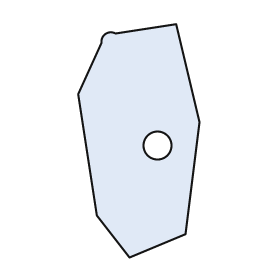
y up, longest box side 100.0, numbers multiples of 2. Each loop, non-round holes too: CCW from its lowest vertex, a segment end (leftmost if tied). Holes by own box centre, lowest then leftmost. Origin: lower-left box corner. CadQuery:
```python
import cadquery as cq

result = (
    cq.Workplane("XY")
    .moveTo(22.0, 0.0)
    .lineTo(46.0, 10.0)
    .lineTo(52.0, 58.0)
    .lineTo(42.0, 100.0)
    .lineTo(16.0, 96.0)
    .threePointArc((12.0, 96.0), (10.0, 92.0))
    .lineTo(0.0, 70.0)
    .lineTo(8.0, 18.0)
    .close()
    .moveTo(34.0, 48.0)
    .circle(6.0)
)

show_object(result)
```